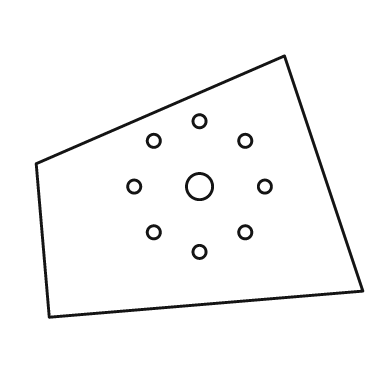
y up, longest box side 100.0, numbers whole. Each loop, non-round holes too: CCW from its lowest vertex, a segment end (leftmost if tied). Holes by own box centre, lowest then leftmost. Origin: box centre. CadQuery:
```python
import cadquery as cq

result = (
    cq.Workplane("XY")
    .moveTo(-46.0, -40.0)
    .lineTo(50.0, -32.0)
    .lineTo(26.0, 40.0)
    .lineTo(-50.0, 7.0)
    .close()
    .moveTo(0.0, -20.0)
    .circle(2.0)
    .moveTo(-14.0, -14.0)
    .circle(2.0)
    .moveTo(14.0, -14.0)
    .circle(2.0)
    .moveTo(-20.0, 0.0)
    .circle(2.0)
    .moveTo(0.0, 0.0)
    .circle(4.0)
    .moveTo(20.0, 0.0)
    .circle(2.0)
    .moveTo(-14.0, 14.0)
    .circle(2.0)
    .moveTo(14.0, 14.0)
    .circle(2.0)
    .moveTo(0.0, 20.0)
    .circle(2.0)
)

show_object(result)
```